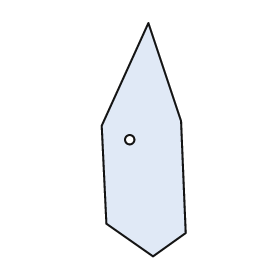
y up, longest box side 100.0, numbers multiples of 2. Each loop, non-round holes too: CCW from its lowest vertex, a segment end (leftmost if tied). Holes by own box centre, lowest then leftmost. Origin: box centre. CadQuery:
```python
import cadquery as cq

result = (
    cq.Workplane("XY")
    .moveTo(4.0, -50.0)
    .lineTo(18.0, -40.0)
    .lineTo(16.0, 8.0)
    .lineTo(2.0, 50.0)
    .lineTo(-18.0, 6.0)
    .lineTo(-16.0, -36.0)
    .close()
    .moveTo(-6.0, 0.0)
    .circle(2.0)
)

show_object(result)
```